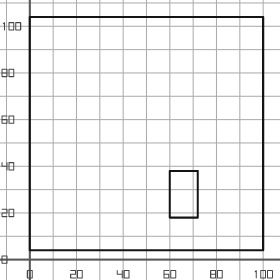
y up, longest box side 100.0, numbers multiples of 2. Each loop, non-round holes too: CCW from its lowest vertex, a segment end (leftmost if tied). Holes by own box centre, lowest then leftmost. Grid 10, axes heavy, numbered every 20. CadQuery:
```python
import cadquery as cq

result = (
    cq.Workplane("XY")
    .moveTo(0.0, 4.0)
    .lineTo(100.0, 4.0)
    .lineTo(100.0, 104.0)
    .lineTo(0.0, 104.0)
    .close()
    .moveTo(60.0, 18.0)
    .lineTo(72.0, 18.0)
    .lineTo(72.0, 38.0)
    .lineTo(60.0, 38.0)
    .close()
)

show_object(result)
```